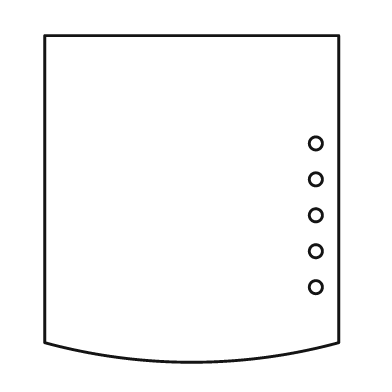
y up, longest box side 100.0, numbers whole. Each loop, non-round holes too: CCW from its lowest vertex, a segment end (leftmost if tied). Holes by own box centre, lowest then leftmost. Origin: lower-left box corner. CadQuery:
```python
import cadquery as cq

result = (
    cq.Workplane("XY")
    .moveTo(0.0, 6.0)
    .threePointArc((45.0, 0.0), (90.0, 6.0))
    .lineTo(90.0, 100.0)
    .lineTo(0.0, 100.0)
    .close()
    .moveTo(83.0, 23.0)
    .circle(2.0)
    .moveTo(83.0, 34.0)
    .circle(2.0)
    .moveTo(83.0, 45.0)
    .circle(2.0)
    .moveTo(83.0, 56.0)
    .circle(2.0)
    .moveTo(83.0, 67.0)
    .circle(2.0)
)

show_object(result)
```